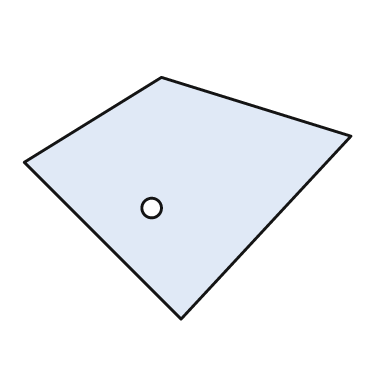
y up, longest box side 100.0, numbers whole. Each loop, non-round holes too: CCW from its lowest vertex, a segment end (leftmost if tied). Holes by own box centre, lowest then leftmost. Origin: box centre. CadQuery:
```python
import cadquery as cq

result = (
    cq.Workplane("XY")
    .moveTo(-2.0, -37.0)
    .lineTo(50.0, 19.0)
    .lineTo(-8.0, 37.0)
    .lineTo(-50.0, 11.0)
    .close()
    .moveTo(-11.0, -3.0)
    .circle(3.0)
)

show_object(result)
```